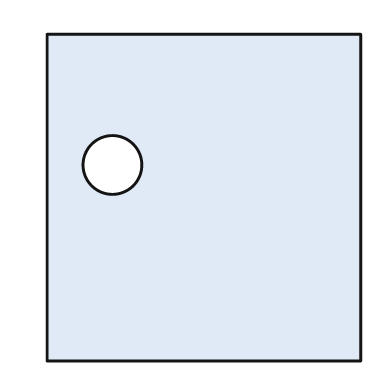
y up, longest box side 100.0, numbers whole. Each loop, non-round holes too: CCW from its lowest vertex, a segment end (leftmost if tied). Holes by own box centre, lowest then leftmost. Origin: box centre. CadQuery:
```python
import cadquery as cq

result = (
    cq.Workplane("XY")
    .moveTo(-48.0, -50.0)
    .lineTo(48.0, -50.0)
    .lineTo(48.0, 50.0)
    .lineTo(-48.0, 50.0)
    .close()
    .moveTo(-28.0, 10.0)
    .circle(9.0)
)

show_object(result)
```